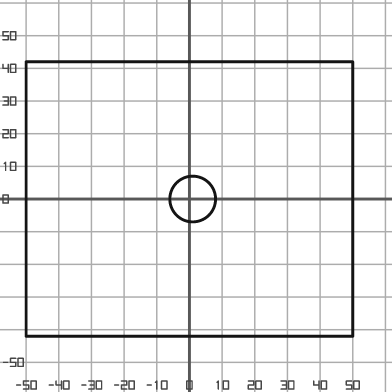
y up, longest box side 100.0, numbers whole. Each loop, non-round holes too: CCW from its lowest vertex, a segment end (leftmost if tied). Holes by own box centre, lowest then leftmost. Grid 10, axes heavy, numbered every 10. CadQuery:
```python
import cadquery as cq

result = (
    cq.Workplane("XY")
    .moveTo(-50.0, -42.0)
    .lineTo(50.0, -42.0)
    .lineTo(50.0, 42.0)
    .lineTo(-50.0, 42.0)
    .close()
    .moveTo(1.0, 0.0)
    .circle(7.0)
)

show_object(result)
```